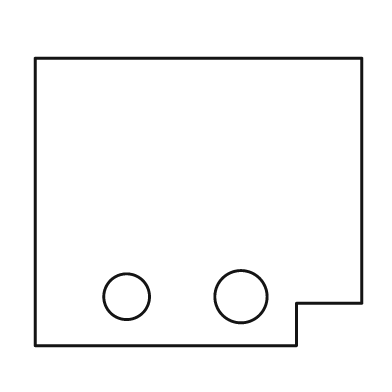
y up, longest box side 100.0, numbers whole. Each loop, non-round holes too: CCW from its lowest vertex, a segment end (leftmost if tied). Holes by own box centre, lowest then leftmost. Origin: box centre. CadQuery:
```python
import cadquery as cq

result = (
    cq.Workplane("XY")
    .moveTo(-50.0, -44.0)
    .lineTo(30.0, -44.0)
    .lineTo(30.0, -31.0)
    .lineTo(50.0, -31.0)
    .lineTo(50.0, 44.0)
    .lineTo(-50.0, 44.0)
    .close()
    .moveTo(-22.0, -29.0)
    .circle(7.0)
    .moveTo(13.0, -29.0)
    .circle(8.0)
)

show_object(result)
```